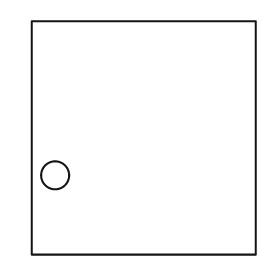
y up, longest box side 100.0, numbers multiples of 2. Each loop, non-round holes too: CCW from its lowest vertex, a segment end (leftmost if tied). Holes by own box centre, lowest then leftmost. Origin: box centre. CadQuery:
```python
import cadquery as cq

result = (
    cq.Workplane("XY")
    .moveTo(-48.0, -50.0)
    .lineTo(48.0, -50.0)
    .lineTo(48.0, 50.0)
    .lineTo(-48.0, 50.0)
    .close()
    .moveTo(-38.0, -16.0)
    .circle(6.0)
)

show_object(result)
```